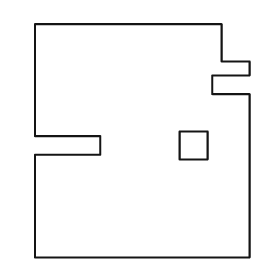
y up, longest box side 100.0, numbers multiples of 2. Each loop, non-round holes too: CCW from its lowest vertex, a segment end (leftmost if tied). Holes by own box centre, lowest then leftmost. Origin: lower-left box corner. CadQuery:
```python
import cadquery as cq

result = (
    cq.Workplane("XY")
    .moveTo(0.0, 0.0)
    .lineTo(92.0, 0.0)
    .lineTo(92.0, 70.0)
    .lineTo(76.0, 70.0)
    .lineTo(76.0, 78.0)
    .lineTo(92.0, 78.0)
    .lineTo(92.0, 84.0)
    .lineTo(80.0, 84.0)
    .lineTo(80.0, 100.0)
    .lineTo(0.0, 100.0)
    .lineTo(0.0, 52.0)
    .lineTo(28.0, 52.0)
    .lineTo(28.0, 44.0)
    .lineTo(0.0, 44.0)
    .close()
    .moveTo(62.0, 42.0)
    .lineTo(74.0, 42.0)
    .lineTo(74.0, 54.0)
    .lineTo(62.0, 54.0)
    .close()
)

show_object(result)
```